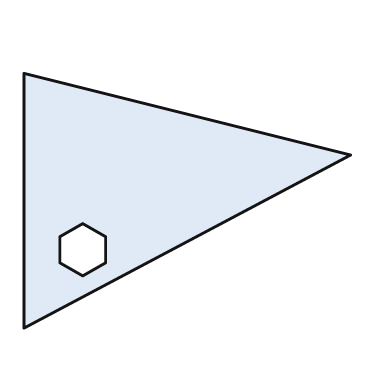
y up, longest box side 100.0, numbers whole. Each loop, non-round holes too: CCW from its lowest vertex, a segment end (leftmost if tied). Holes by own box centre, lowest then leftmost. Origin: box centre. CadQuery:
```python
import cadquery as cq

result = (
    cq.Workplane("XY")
    .moveTo(-50.0, -39.0)
    .lineTo(50.0, 14.0)
    .lineTo(-50.0, 39.0)
    .close()
    .moveTo(-32.0, -23.0)
    .lineTo(-25.0, -19.0)
    .lineTo(-25.0, -11.0)
    .lineTo(-32.0, -7.0)
    .lineTo(-39.0, -11.0)
    .lineTo(-39.0, -19.0)
    .close()
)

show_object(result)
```